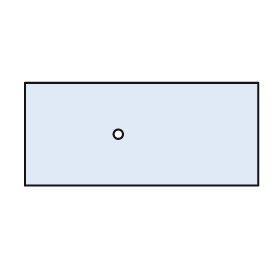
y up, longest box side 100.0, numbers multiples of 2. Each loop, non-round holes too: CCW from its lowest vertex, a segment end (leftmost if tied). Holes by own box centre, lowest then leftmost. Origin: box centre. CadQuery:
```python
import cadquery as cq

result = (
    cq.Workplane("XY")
    .moveTo(-50.0, -22.0)
    .lineTo(50.0, -22.0)
    .lineTo(50.0, 22.0)
    .lineTo(-50.0, 22.0)
    .close()
    .moveTo(-10.0, 0.0)
    .circle(2.0)
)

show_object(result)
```